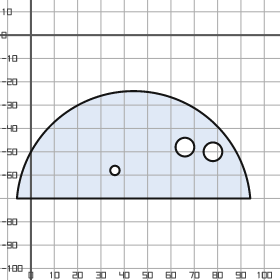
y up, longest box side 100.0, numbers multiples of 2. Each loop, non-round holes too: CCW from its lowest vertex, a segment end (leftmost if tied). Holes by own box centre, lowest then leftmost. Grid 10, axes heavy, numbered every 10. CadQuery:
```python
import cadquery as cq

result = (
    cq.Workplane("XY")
    .moveTo(-6.0, -70.0)
    .lineTo(94.0, -70.0)
    .threePointArc((44.0, -24.0), (-6.0, -70.0))
    .close()
    .moveTo(36.0, -58.0)
    .circle(2.0)
    .moveTo(78.0, -50.0)
    .circle(4.0)
    .moveTo(66.0, -48.0)
    .circle(4.0)
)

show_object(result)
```